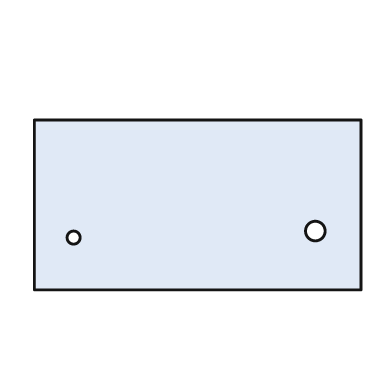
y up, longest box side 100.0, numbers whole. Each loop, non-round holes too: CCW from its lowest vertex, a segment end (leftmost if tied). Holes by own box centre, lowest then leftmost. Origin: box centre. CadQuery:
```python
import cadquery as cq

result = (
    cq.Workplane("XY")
    .moveTo(-50.0, -26.0)
    .lineTo(50.0, -26.0)
    .lineTo(50.0, 26.0)
    .lineTo(-50.0, 26.0)
    .close()
    .moveTo(-38.0, -10.0)
    .circle(2.0)
    .moveTo(36.0, -8.0)
    .circle(3.0)
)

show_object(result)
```